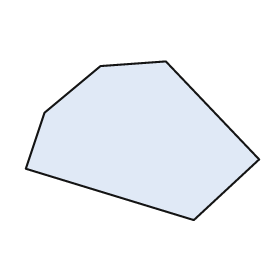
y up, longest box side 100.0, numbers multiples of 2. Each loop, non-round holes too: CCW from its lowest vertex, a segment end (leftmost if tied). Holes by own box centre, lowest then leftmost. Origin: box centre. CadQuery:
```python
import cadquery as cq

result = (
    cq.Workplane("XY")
    .moveTo(22.0, -34.0)
    .lineTo(50.0, -8.0)
    .lineTo(10.0, 34.0)
    .lineTo(-18.0, 32.0)
    .lineTo(-42.0, 12.0)
    .lineTo(-50.0, -12.0)
    .close()
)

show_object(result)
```